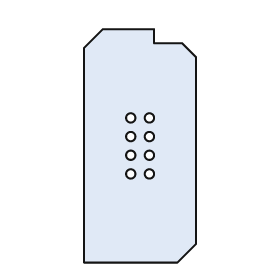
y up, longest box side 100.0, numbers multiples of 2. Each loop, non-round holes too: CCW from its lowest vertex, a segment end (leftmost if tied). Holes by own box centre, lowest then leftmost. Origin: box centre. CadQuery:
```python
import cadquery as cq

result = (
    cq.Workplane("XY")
    .moveTo(-24.0, -50.0)
    .lineTo(16.0, -50.0)
    .lineTo(24.0, -42.0)
    .lineTo(24.0, 38.0)
    .lineTo(18.0, 44.0)
    .lineTo(6.0, 44.0)
    .lineTo(6.0, 50.0)
    .lineTo(-16.0, 50.0)
    .lineTo(-24.0, 42.0)
    .close()
    .moveTo(-4.0, -12.0)
    .circle(2.0)
    .moveTo(4.0, -12.0)
    .circle(2.0)
    .moveTo(-4.0, -4.0)
    .circle(2.0)
    .moveTo(4.0, -4.0)
    .circle(2.0)
    .moveTo(-4.0, 4.0)
    .circle(2.0)
    .moveTo(4.0, 4.0)
    .circle(2.0)
    .moveTo(-4.0, 12.0)
    .circle(2.0)
    .moveTo(4.0, 12.0)
    .circle(2.0)
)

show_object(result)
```